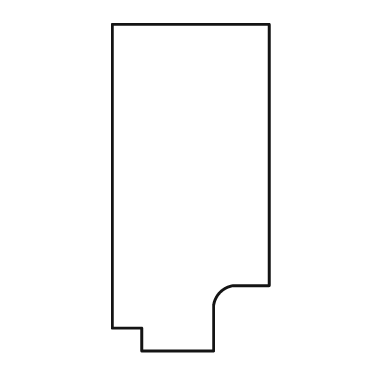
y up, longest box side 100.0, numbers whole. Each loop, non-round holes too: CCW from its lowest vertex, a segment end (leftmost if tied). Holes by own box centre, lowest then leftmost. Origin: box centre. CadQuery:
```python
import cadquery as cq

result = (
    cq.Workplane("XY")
    .moveTo(-15.0, -50.0)
    .lineTo(7.0, -50.0)
    .lineTo(7.0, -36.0)
    .threePointArc((9.0, -32.0), (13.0, -30.0))
    .lineTo(24.0, -30.0)
    .lineTo(24.0, 50.0)
    .lineTo(-24.0, 50.0)
    .lineTo(-24.0, -43.0)
    .lineTo(-15.0, -43.0)
    .close()
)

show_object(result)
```